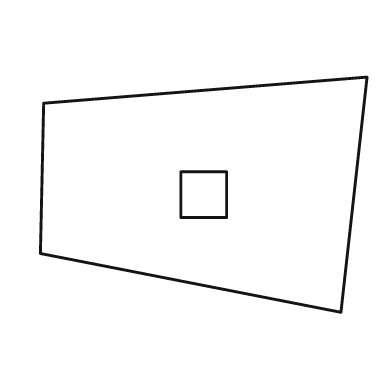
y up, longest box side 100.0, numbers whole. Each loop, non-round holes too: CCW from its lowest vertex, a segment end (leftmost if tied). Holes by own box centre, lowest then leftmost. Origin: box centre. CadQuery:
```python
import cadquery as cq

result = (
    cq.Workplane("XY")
    .moveTo(42.0, -36.0)
    .lineTo(50.0, 36.0)
    .lineTo(-49.0, 28.0)
    .lineTo(-50.0, -18.0)
    .close()
    .moveTo(-7.0, -7.0)
    .lineTo(7.0, -7.0)
    .lineTo(7.0, 7.0)
    .lineTo(-7.0, 7.0)
    .close()
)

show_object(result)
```